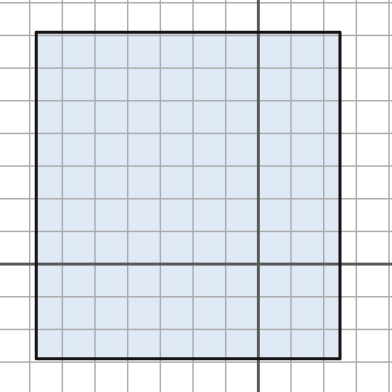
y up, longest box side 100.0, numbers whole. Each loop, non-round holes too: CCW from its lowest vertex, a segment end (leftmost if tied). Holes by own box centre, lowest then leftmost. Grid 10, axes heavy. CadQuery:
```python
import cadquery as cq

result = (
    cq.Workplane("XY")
    .moveTo(-68.0, -29.0)
    .lineTo(25.0, -29.0)
    .lineTo(25.0, 71.0)
    .lineTo(-68.0, 71.0)
    .close()
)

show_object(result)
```